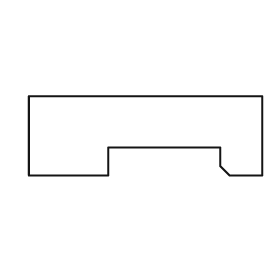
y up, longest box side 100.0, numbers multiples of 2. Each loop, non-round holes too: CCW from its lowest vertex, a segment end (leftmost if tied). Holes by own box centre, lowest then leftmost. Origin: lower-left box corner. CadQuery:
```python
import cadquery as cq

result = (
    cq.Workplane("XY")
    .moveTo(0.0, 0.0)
    .lineTo(34.0, 0.0)
    .lineTo(34.0, 12.0)
    .lineTo(82.0, 12.0)
    .lineTo(82.0, 4.0)
    .lineTo(86.0, 0.0)
    .lineTo(100.0, 0.0)
    .lineTo(100.0, 34.0)
    .lineTo(0.0, 34.0)
    .close()
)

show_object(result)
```